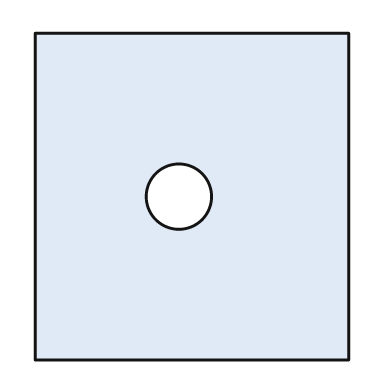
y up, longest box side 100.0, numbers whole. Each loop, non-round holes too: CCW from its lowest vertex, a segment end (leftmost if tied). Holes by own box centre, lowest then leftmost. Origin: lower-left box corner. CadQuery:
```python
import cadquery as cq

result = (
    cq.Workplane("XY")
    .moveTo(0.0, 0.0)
    .lineTo(96.0, 0.0)
    .lineTo(96.0, 100.0)
    .lineTo(0.0, 100.0)
    .close()
    .moveTo(44.0, 50.0)
    .circle(10.0)
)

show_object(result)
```